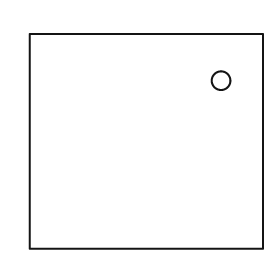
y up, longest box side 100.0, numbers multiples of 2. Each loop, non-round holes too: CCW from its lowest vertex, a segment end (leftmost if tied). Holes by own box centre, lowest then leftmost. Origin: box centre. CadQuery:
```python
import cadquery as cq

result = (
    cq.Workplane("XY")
    .moveTo(-50.0, -46.0)
    .lineTo(50.0, -46.0)
    .lineTo(50.0, 46.0)
    .lineTo(-50.0, 46.0)
    .close()
    .moveTo(32.0, 26.0)
    .circle(4.0)
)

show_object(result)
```